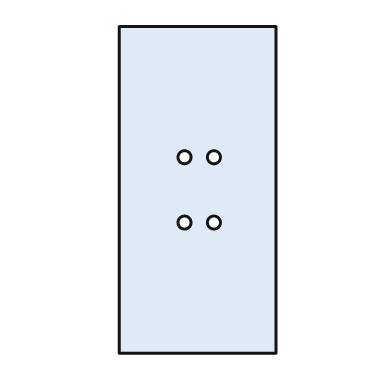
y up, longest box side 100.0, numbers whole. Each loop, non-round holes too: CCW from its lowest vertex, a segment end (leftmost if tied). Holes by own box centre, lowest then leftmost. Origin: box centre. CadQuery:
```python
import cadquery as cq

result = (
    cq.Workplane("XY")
    .moveTo(-24.0, -50.0)
    .lineTo(24.0, -50.0)
    .lineTo(24.0, 50.0)
    .lineTo(-24.0, 50.0)
    .close()
    .moveTo(-4.0, -10.0)
    .circle(2.0)
    .moveTo(5.0, -10.0)
    .circle(2.0)
    .moveTo(-4.0, 10.0)
    .circle(2.0)
    .moveTo(5.0, 10.0)
    .circle(2.0)
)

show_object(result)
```